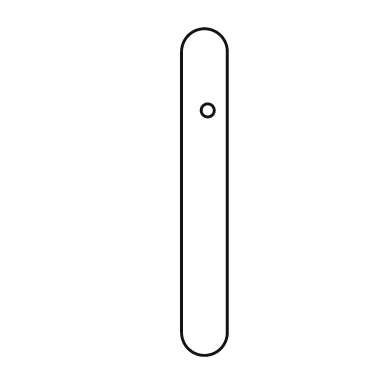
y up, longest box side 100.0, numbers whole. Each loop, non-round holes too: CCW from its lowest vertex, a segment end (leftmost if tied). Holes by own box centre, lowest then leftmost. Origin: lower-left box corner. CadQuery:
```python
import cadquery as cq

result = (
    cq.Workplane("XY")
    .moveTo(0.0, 7.0)
    .threePointArc((7.0, 0.0), (14.0, 7.0))
    .lineTo(14.0, 93.0)
    .threePointArc((7.0, 100.0), (0.0, 93.0))
    .close()
    .moveTo(8.0, 75.0)
    .circle(2.0)
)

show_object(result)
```